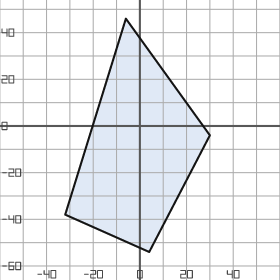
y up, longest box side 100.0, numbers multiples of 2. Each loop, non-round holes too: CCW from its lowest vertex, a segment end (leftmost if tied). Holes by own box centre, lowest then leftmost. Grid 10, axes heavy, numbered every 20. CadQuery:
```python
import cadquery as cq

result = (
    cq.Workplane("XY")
    .moveTo(4.0, -54.0)
    .lineTo(30.0, -4.0)
    .lineTo(-6.0, 46.0)
    .lineTo(-32.0, -38.0)
    .close()
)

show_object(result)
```